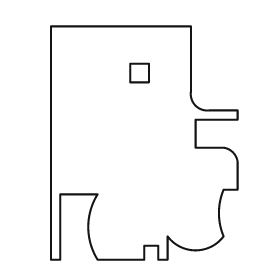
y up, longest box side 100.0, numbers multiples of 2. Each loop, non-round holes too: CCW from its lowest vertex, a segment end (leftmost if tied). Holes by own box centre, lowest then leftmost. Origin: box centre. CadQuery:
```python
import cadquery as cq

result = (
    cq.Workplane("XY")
    .moveTo(-40.0, -50.0)
    .lineTo(-36.0, -50.0)
    .lineTo(-36.0, -22.0)
    .lineTo(-20.0, -22.0)
    .threePointArc((-24.0, -36.0), (-20.0, -50.0))
    .lineTo(0.0, -50.0)
    .lineTo(0.0, -44.0)
    .lineTo(6.0, -44.0)
    .lineTo(6.0, -50.0)
    .lineTo(10.0, -50.0)
    .lineTo(10.0, -40.0)
    .threePointArc((22.0, -46.0), (34.0, -40.0))
    .threePointArc((32.0, -30.0), (34.0, -20.0))
    .lineTo(40.0, -20.0)
    .lineTo(40.0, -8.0)
    .threePointArc((38.0, -4.0), (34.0, -2.0))
    .lineTo(22.0, -2.0)
    .lineTo(22.0, 10.0)
    .lineTo(40.0, 10.0)
    .lineTo(40.0, 14.0)
    .lineTo(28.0, 14.0)
    .threePointArc((22.0, 16.0), (20.0, 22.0))
    .lineTo(20.0, 50.0)
    .lineTo(-40.0, 50.0)
    .close()
    .moveTo(-6.0, 26.0)
    .lineTo(2.0, 26.0)
    .lineTo(2.0, 34.0)
    .lineTo(-6.0, 34.0)
    .close()
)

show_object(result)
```